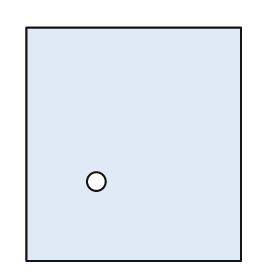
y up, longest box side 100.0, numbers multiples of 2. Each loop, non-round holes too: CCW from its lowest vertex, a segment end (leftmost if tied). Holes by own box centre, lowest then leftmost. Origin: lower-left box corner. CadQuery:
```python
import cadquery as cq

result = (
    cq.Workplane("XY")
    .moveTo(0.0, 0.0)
    .lineTo(92.0, 0.0)
    .lineTo(92.0, 100.0)
    .lineTo(0.0, 100.0)
    .close()
    .moveTo(30.0, 34.0)
    .circle(4.0)
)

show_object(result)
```